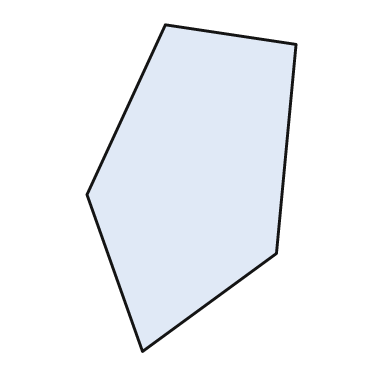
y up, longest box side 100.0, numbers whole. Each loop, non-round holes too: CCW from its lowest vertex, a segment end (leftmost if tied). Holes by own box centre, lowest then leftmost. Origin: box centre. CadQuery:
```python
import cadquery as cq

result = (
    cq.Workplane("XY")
    .moveTo(-15.0, -50.0)
    .lineTo(26.0, -20.0)
    .lineTo(32.0, 44.0)
    .lineTo(-8.0, 50.0)
    .lineTo(-32.0, -2.0)
    .close()
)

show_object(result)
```